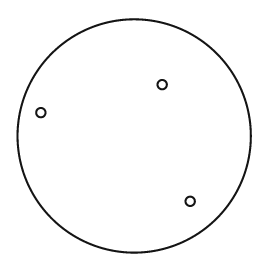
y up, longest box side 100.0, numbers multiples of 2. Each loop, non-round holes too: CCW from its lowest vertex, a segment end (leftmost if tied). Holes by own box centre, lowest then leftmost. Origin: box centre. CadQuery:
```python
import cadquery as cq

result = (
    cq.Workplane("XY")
    .moveTo(0.0, 0.0)
    .circle(50.0)
    .moveTo(24.0, -28.0)
    .circle(2.0)
    .moveTo(-40.0, 10.0)
    .circle(2.0)
    .moveTo(12.0, 22.0)
    .circle(2.0)
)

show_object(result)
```